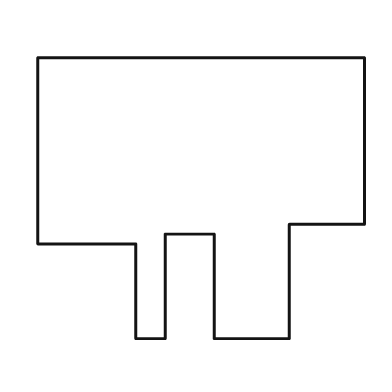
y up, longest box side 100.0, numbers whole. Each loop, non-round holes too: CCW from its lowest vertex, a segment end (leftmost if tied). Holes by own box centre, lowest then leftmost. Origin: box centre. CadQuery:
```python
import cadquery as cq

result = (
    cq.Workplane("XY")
    .moveTo(-20.0, -43.0)
    .lineTo(-11.0, -43.0)
    .lineTo(-11.0, -11.0)
    .lineTo(4.0, -11.0)
    .lineTo(4.0, -43.0)
    .lineTo(27.0, -43.0)
    .lineTo(27.0, -8.0)
    .lineTo(50.0, -8.0)
    .lineTo(50.0, 43.0)
    .lineTo(-50.0, 43.0)
    .lineTo(-50.0, -14.0)
    .lineTo(-20.0, -14.0)
    .close()
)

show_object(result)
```